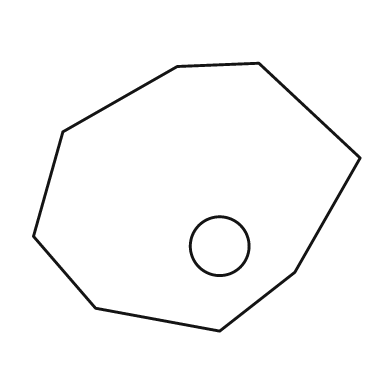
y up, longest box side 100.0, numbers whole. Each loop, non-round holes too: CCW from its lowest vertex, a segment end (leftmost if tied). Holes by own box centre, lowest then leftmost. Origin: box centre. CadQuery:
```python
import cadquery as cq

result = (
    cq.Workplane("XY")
    .moveTo(7.0, -41.0)
    .lineTo(30.0, -23.0)
    .lineTo(50.0, 12.0)
    .lineTo(19.0, 41.0)
    .lineTo(-6.0, 40.0)
    .lineTo(-41.0, 20.0)
    .lineTo(-50.0, -12.0)
    .lineTo(-31.0, -34.0)
    .close()
    .moveTo(7.0, -15.0)
    .circle(9.0)
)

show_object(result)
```